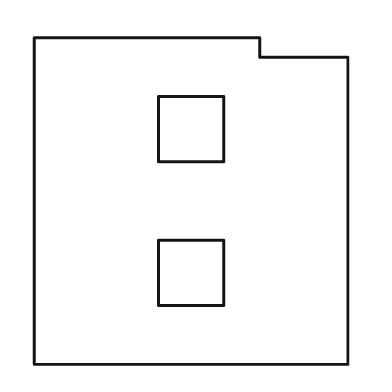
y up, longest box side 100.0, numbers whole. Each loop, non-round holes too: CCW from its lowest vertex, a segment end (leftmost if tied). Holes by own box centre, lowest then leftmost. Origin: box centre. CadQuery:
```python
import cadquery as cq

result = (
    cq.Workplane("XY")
    .moveTo(-48.0, -50.0)
    .lineTo(48.0, -50.0)
    .lineTo(48.0, 44.0)
    .lineTo(21.0, 44.0)
    .lineTo(21.0, 50.0)
    .lineTo(-48.0, 50.0)
    .close()
    .moveTo(-10.0, -32.0)
    .lineTo(10.0, -32.0)
    .lineTo(10.0, -12.0)
    .lineTo(-10.0, -12.0)
    .close()
    .moveTo(-10.0, 12.0)
    .lineTo(10.0, 12.0)
    .lineTo(10.0, 32.0)
    .lineTo(-10.0, 32.0)
    .close()
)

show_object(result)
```